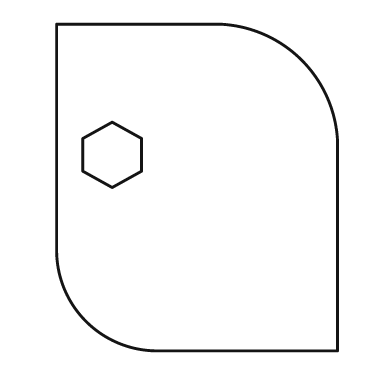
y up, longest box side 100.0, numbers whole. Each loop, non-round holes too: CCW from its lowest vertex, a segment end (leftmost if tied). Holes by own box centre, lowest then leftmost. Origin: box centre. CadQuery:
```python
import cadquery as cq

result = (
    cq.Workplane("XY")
    .moveTo(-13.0, -50.0)
    .lineTo(43.0, -50.0)
    .lineTo(43.0, 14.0)
    .threePointArc((32.0, 39.0), (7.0, 50.0))
    .lineTo(-43.0, 50.0)
    .lineTo(-43.0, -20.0)
    .threePointArc((-34.0, -41.0), (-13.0, -50.0))
    .close()
    .moveTo(-26.0, 0.0)
    .lineTo(-17.0, 5.0)
    .lineTo(-17.0, 15.0)
    .lineTo(-26.0, 20.0)
    .lineTo(-35.0, 15.0)
    .lineTo(-35.0, 5.0)
    .close()
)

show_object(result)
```